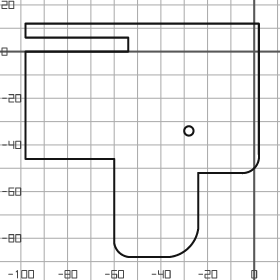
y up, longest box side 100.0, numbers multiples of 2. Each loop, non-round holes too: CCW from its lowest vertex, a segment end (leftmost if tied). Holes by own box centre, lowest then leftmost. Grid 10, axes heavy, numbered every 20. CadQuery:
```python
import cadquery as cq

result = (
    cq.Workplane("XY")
    .moveTo(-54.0, -88.0)
    .lineTo(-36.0, -88.0)
    .threePointArc((-28.0, -84.0), (-24.0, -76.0))
    .lineTo(-24.0, -52.0)
    .lineTo(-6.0, -52.0)
    .threePointArc((0.0, -50.0), (2.0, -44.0))
    .lineTo(2.0, 12.0)
    .lineTo(-98.0, 12.0)
    .lineTo(-98.0, 6.0)
    .lineTo(-54.0, 6.0)
    .lineTo(-54.0, 0.0)
    .lineTo(-98.0, 0.0)
    .lineTo(-98.0, -46.0)
    .lineTo(-60.0, -46.0)
    .lineTo(-60.0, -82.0)
    .threePointArc((-58.0, -86.0), (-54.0, -88.0))
    .close()
    .moveTo(-28.0, -34.0)
    .circle(2.0)
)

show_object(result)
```